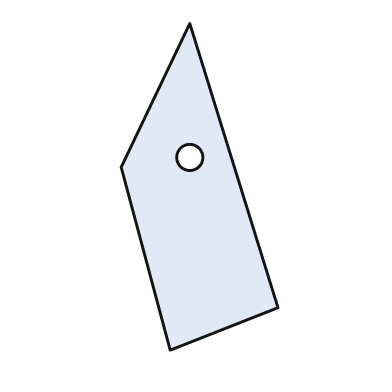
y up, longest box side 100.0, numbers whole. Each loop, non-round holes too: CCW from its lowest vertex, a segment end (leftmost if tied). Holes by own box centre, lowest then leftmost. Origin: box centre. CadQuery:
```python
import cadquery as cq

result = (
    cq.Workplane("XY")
    .moveTo(-9.0, -50.0)
    .lineTo(24.0, -37.0)
    .lineTo(-3.0, 50.0)
    .lineTo(-24.0, 6.0)
    .close()
    .moveTo(-3.0, 9.0)
    .circle(4.0)
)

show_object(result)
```